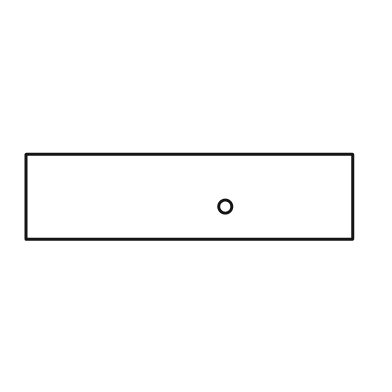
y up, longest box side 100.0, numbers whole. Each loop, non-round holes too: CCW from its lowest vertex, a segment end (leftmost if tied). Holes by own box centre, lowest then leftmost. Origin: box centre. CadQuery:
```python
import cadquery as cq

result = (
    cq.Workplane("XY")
    .moveTo(-50.0, -13.0)
    .lineTo(50.0, -13.0)
    .lineTo(50.0, 13.0)
    .lineTo(-50.0, 13.0)
    .close()
    .moveTo(11.0, -3.0)
    .circle(2.0)
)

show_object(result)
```